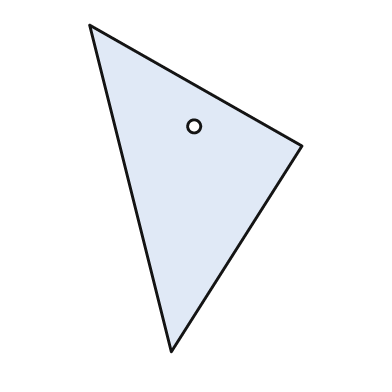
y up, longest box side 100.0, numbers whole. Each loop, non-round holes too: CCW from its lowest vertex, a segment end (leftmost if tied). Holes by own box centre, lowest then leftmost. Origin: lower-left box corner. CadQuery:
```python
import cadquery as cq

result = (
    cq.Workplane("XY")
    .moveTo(25.0, 0.0)
    .lineTo(65.0, 63.0)
    .lineTo(0.0, 100.0)
    .close()
    .moveTo(32.0, 69.0)
    .circle(2.0)
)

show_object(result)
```